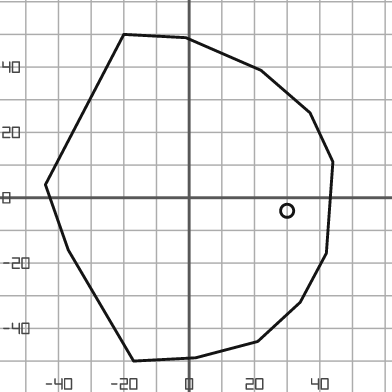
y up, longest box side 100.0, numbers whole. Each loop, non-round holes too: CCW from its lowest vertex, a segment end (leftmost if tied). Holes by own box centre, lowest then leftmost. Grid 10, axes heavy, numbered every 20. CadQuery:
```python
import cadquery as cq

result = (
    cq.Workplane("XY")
    .moveTo(-17.0, -50.0)
    .lineTo(2.0, -49.0)
    .lineTo(21.0, -44.0)
    .lineTo(34.0, -32.0)
    .lineTo(42.0, -17.0)
    .lineTo(44.0, 11.0)
    .lineTo(37.0, 26.0)
    .lineTo(22.0, 39.0)
    .lineTo(-1.0, 49.0)
    .lineTo(-20.0, 50.0)
    .lineTo(-44.0, 4.0)
    .lineTo(-37.0, -16.0)
    .close()
    .moveTo(30.0, -4.0)
    .circle(2.0)
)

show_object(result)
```